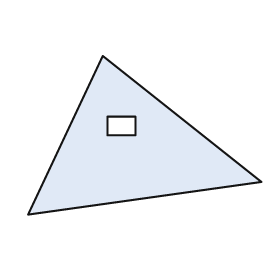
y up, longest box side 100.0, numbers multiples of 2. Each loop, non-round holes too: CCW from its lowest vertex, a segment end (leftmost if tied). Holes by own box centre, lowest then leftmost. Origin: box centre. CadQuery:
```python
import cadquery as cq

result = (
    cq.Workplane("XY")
    .moveTo(-50.0, -34.0)
    .lineTo(50.0, -20.0)
    .lineTo(-18.0, 34.0)
    .close()
    .moveTo(-16.0, 0.0)
    .lineTo(-4.0, 0.0)
    .lineTo(-4.0, 8.0)
    .lineTo(-16.0, 8.0)
    .close()
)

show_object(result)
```